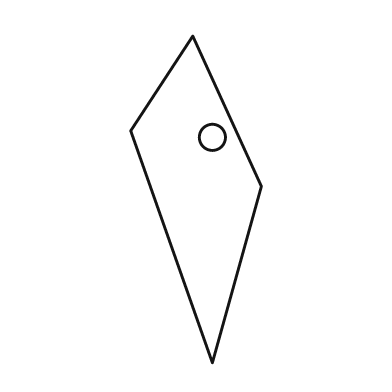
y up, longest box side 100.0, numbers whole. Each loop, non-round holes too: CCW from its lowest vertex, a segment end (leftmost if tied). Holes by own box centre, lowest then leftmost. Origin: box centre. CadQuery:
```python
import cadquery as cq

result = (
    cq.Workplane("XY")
    .moveTo(5.0, -50.0)
    .lineTo(20.0, 4.0)
    .lineTo(-1.0, 50.0)
    .lineTo(-20.0, 21.0)
    .close()
    .moveTo(5.0, 19.0)
    .circle(4.0)
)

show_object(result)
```